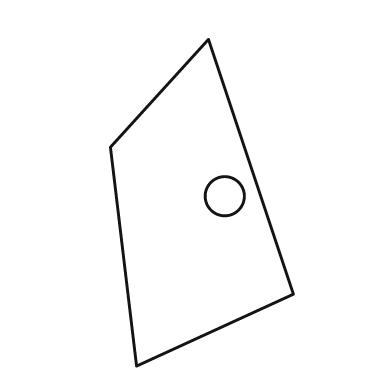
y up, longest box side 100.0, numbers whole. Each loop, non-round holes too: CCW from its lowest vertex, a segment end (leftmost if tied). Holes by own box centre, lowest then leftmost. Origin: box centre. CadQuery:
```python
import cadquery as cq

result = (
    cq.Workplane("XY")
    .moveTo(-20.0, -50.0)
    .lineTo(28.0, -28.0)
    .lineTo(2.0, 50.0)
    .lineTo(-28.0, 17.0)
    .close()
    .moveTo(7.0, 2.0)
    .circle(6.0)
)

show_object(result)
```